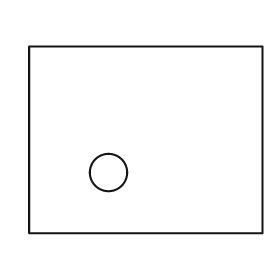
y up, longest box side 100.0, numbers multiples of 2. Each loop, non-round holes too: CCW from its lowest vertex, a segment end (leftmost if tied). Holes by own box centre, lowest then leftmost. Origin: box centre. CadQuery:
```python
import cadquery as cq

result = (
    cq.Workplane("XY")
    .moveTo(-50.0, -40.0)
    .lineTo(50.0, -40.0)
    .lineTo(50.0, 40.0)
    .lineTo(-50.0, 40.0)
    .close()
    .moveTo(-16.0, -14.0)
    .circle(8.0)
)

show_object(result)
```